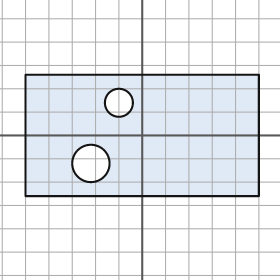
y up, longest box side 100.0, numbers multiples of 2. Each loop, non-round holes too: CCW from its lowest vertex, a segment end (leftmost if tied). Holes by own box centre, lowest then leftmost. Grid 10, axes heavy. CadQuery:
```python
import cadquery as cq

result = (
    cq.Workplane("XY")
    .moveTo(-50.0, -26.0)
    .lineTo(50.0, -26.0)
    .lineTo(50.0, 26.0)
    .lineTo(-50.0, 26.0)
    .close()
    .moveTo(-22.0, -12.0)
    .circle(8.0)
    .moveTo(-10.0, 14.0)
    .circle(6.0)
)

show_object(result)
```